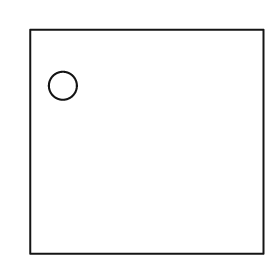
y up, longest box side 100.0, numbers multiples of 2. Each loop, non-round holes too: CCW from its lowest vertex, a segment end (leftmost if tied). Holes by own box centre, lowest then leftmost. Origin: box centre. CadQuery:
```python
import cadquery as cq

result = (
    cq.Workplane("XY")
    .moveTo(-50.0, -48.0)
    .lineTo(50.0, -48.0)
    .lineTo(50.0, 48.0)
    .lineTo(-50.0, 48.0)
    .close()
    .moveTo(-36.0, 24.0)
    .circle(6.0)
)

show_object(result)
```